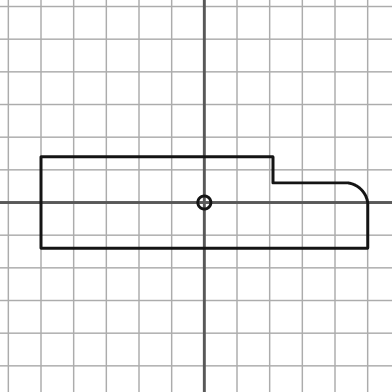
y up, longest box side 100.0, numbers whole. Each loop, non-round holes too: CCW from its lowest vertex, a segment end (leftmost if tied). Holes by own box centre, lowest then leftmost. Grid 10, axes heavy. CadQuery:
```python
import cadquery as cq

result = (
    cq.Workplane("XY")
    .moveTo(-50.0, -14.0)
    .lineTo(50.0, -14.0)
    .lineTo(50.0, 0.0)
    .threePointArc((48.0, 4.0), (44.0, 6.0))
    .lineTo(21.0, 6.0)
    .lineTo(21.0, 14.0)
    .lineTo(-50.0, 14.0)
    .close()
    .moveTo(0.0, 0.0)
    .circle(2.0)
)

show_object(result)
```